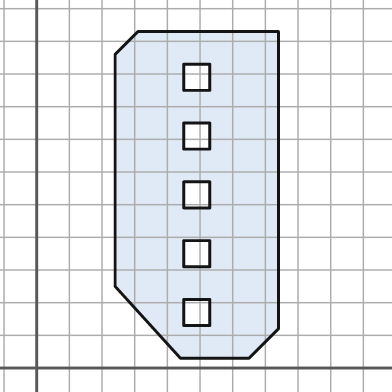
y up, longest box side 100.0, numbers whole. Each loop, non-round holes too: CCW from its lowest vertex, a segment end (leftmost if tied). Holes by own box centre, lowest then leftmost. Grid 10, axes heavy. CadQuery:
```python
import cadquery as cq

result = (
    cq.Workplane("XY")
    .moveTo(44.0, 3.0)
    .lineTo(65.0, 3.0)
    .lineTo(74.0, 12.0)
    .lineTo(74.0, 103.0)
    .lineTo(31.0, 103.0)
    .lineTo(24.0, 96.0)
    .lineTo(24.0, 25.0)
    .close()
    .moveTo(45.0, 13.0)
    .lineTo(53.0, 13.0)
    .lineTo(53.0, 21.0)
    .lineTo(45.0, 21.0)
    .close()
    .moveTo(45.0, 31.0)
    .lineTo(53.0, 31.0)
    .lineTo(53.0, 39.0)
    .lineTo(45.0, 39.0)
    .close()
    .moveTo(45.0, 49.0)
    .lineTo(53.0, 49.0)
    .lineTo(53.0, 57.0)
    .lineTo(45.0, 57.0)
    .close()
    .moveTo(45.0, 67.0)
    .lineTo(53.0, 67.0)
    .lineTo(53.0, 75.0)
    .lineTo(45.0, 75.0)
    .close()
    .moveTo(45.0, 85.0)
    .lineTo(53.0, 85.0)
    .lineTo(53.0, 93.0)
    .lineTo(45.0, 93.0)
    .close()
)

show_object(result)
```